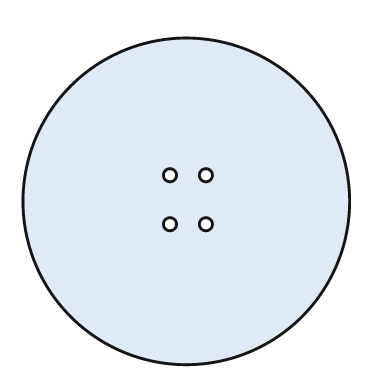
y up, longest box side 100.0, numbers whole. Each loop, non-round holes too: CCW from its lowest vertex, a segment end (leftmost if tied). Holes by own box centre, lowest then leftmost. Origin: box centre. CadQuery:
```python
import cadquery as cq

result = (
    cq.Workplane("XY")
    .moveTo(0.0, 0.0)
    .circle(50.0)
    .moveTo(-5.0, -7.0)
    .circle(2.0)
    .moveTo(6.0, -7.0)
    .circle(2.0)
    .moveTo(-5.0, 8.0)
    .circle(2.0)
    .moveTo(6.0, 8.0)
    .circle(2.0)
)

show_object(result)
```